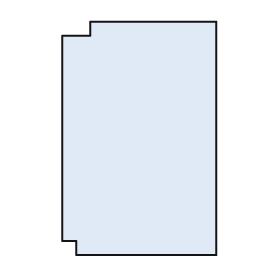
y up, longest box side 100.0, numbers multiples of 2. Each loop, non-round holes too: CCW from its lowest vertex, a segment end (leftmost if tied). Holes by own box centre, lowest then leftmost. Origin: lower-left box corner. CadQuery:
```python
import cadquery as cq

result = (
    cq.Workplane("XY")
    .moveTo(6.0, 0.0)
    .lineTo(66.0, 0.0)
    .lineTo(66.0, 100.0)
    .lineTo(12.0, 100.0)
    .lineTo(12.0, 94.0)
    .lineTo(0.0, 94.0)
    .lineTo(0.0, 6.0)
    .lineTo(6.0, 6.0)
    .close()
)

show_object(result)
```